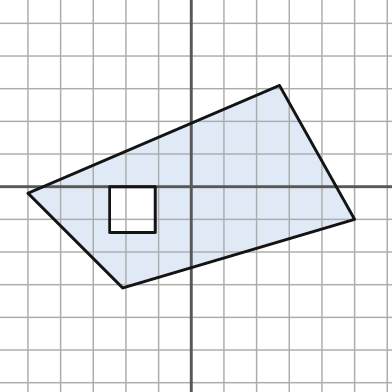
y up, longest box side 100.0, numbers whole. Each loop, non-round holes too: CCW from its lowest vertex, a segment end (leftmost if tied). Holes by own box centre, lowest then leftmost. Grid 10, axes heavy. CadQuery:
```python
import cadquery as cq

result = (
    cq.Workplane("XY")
    .moveTo(-21.0, -31.0)
    .lineTo(50.0, -10.0)
    .lineTo(27.0, 31.0)
    .lineTo(-50.0, -2.0)
    .close()
    .moveTo(-25.0, -14.0)
    .lineTo(-11.0, -14.0)
    .lineTo(-11.0, 0.0)
    .lineTo(-25.0, 0.0)
    .close()
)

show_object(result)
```